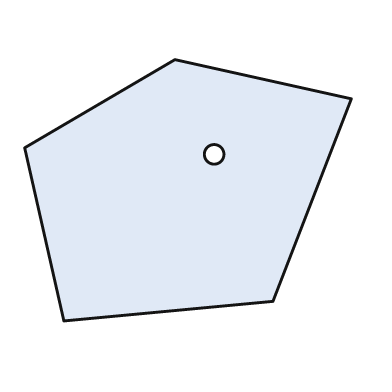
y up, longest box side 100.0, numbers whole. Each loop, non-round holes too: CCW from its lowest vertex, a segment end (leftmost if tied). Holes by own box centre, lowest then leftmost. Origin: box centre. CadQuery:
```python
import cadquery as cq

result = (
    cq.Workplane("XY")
    .moveTo(-38.0, -40.0)
    .lineTo(26.0, -34.0)
    .lineTo(50.0, 28.0)
    .lineTo(-4.0, 40.0)
    .lineTo(-50.0, 13.0)
    .close()
    .moveTo(8.0, 11.0)
    .circle(3.0)
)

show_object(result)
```